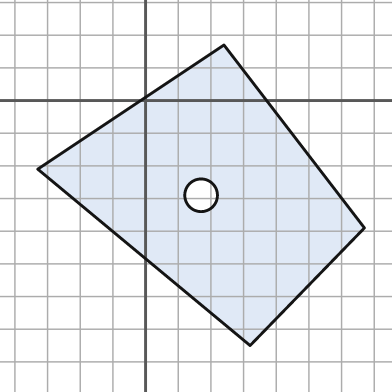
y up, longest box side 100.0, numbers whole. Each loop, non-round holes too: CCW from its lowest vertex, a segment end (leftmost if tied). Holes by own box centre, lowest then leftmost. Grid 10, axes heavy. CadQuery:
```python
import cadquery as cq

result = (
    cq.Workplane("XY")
    .moveTo(32.0, -75.0)
    .lineTo(67.0, -39.0)
    .lineTo(24.0, 17.0)
    .lineTo(-33.0, -21.0)
    .close()
    .moveTo(17.0, -29.0)
    .circle(5.0)
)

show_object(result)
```